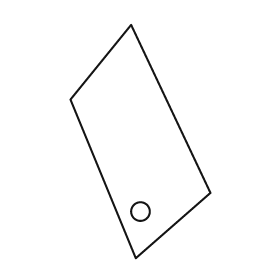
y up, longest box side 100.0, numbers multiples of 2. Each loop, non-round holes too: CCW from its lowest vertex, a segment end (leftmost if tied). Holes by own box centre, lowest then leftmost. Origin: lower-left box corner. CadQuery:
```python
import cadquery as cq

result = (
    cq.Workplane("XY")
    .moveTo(28.0, 0.0)
    .lineTo(60.0, 28.0)
    .lineTo(26.0, 100.0)
    .lineTo(0.0, 68.0)
    .close()
    .moveTo(30.0, 20.0)
    .circle(4.0)
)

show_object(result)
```